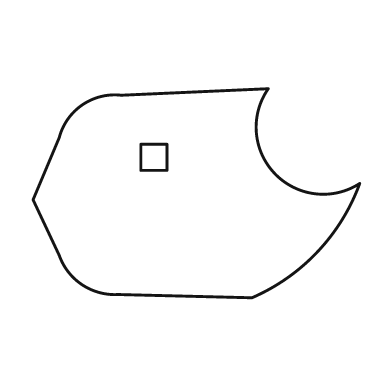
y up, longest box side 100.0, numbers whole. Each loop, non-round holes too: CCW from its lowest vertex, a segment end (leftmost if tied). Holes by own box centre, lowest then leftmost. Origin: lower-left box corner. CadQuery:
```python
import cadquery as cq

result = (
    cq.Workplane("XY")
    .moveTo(67.0, 0.0)
    .threePointArc((87.0, 14.0), (100.0, 35.0))
    .threePointArc((74.0, 38.0), (72.0, 64.0))
    .lineTo(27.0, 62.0)
    .threePointArc((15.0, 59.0), (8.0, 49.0))
    .lineTo(0.0, 30.0)
    .lineTo(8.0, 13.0)
    .threePointArc((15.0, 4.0), (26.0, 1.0))
    .close()
    .moveTo(33.0, 39.0)
    .lineTo(41.0, 39.0)
    .lineTo(41.0, 47.0)
    .lineTo(33.0, 47.0)
    .close()
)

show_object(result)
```